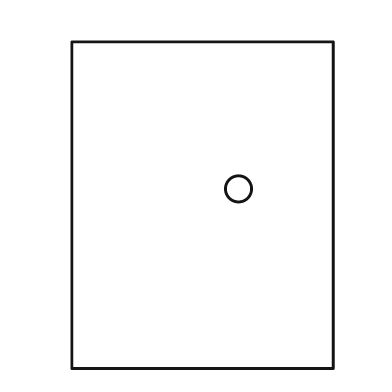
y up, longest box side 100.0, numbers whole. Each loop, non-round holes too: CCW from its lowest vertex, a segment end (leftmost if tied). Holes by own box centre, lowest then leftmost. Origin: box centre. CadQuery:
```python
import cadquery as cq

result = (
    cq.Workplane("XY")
    .moveTo(-40.0, -50.0)
    .lineTo(40.0, -50.0)
    .lineTo(40.0, 50.0)
    .lineTo(-40.0, 50.0)
    .close()
    .moveTo(11.0, 5.0)
    .circle(4.0)
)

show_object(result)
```